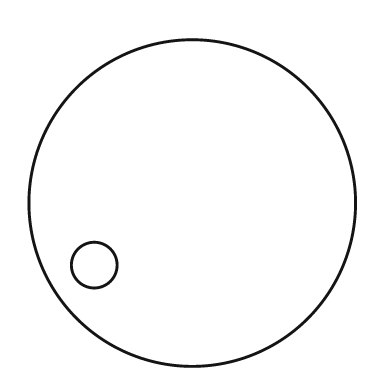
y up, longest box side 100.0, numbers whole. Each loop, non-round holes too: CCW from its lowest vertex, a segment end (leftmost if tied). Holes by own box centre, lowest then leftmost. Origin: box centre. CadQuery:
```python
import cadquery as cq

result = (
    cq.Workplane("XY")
    .moveTo(0.0, 0.0)
    .circle(50.0)
    .moveTo(-30.0, -19.0)
    .circle(7.0)
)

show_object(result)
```